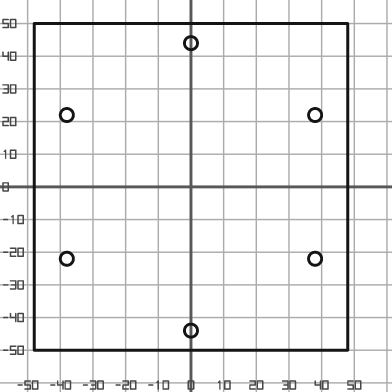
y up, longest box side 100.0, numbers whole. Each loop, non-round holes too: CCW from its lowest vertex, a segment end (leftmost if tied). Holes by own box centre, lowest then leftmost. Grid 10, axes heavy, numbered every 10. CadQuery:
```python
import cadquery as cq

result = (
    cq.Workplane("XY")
    .moveTo(-48.0, -50.0)
    .lineTo(48.0, -50.0)
    .lineTo(48.0, 50.0)
    .lineTo(-48.0, 50.0)
    .close()
    .moveTo(0.0, -44.0)
    .circle(2.0)
    .moveTo(-38.0, -22.0)
    .circle(2.0)
    .moveTo(38.0, -22.0)
    .circle(2.0)
    .moveTo(-38.0, 22.0)
    .circle(2.0)
    .moveTo(38.0, 22.0)
    .circle(2.0)
    .moveTo(0.0, 44.0)
    .circle(2.0)
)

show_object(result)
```